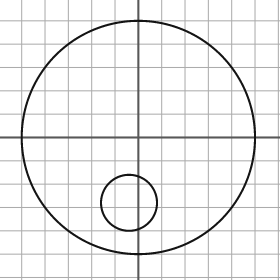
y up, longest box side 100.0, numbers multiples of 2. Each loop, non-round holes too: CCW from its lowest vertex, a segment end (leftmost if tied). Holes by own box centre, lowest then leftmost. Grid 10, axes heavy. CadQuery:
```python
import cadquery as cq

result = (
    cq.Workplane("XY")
    .moveTo(0.0, 0.0)
    .circle(50.0)
    .moveTo(-4.0, -28.0)
    .circle(12.0)
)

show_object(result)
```